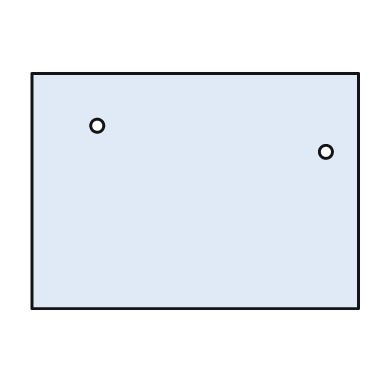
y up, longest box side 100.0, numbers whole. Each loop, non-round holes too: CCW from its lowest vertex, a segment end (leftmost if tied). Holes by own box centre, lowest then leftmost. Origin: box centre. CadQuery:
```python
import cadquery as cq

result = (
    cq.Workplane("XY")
    .moveTo(-50.0, -36.0)
    .lineTo(50.0, -36.0)
    .lineTo(50.0, 36.0)
    .lineTo(-50.0, 36.0)
    .close()
    .moveTo(40.0, 12.0)
    .circle(2.0)
    .moveTo(-30.0, 20.0)
    .circle(2.0)
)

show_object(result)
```